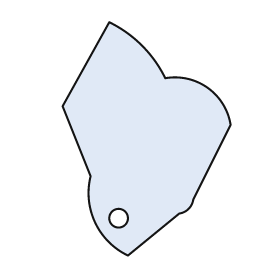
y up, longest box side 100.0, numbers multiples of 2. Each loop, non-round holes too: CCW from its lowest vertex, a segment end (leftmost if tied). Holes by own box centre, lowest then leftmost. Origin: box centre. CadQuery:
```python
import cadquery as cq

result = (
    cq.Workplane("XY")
    .moveTo(-8.0, -50.0)
    .lineTo(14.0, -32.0)
    .threePointArc((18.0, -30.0), (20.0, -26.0))
    .lineTo(36.0, 6.0)
    .threePointArc((26.0, 22.0), (8.0, 26.0))
    .threePointArc((-2.0, 40.0), (-16.0, 50.0))
    .lineTo(-36.0, 14.0)
    .lineTo(-24.0, -16.0)
    .threePointArc((-22.0, -36.0), (-8.0, -50.0))
    .close()
    .moveTo(-12.0, -34.0)
    .circle(4.0)
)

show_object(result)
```